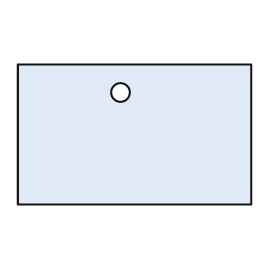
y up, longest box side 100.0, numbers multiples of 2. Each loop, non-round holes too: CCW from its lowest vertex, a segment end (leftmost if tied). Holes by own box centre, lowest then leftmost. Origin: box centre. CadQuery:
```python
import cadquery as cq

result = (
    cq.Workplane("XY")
    .moveTo(-50.0, -30.0)
    .lineTo(50.0, -30.0)
    .lineTo(50.0, 30.0)
    .lineTo(-50.0, 30.0)
    .close()
    .moveTo(-6.0, 18.0)
    .circle(4.0)
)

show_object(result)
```